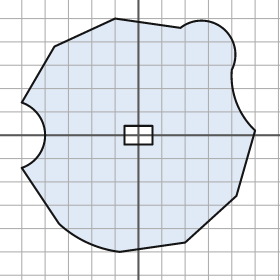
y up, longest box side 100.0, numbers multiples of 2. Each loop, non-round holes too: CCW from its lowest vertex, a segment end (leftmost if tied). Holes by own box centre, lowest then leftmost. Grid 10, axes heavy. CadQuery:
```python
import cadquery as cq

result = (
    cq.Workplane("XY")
    .moveTo(-8.0, -50.0)
    .lineTo(20.0, -46.0)
    .lineTo(42.0, -26.0)
    .lineTo(50.0, 2.0)
    .threePointArc((42.0, 14.0), (40.0, 28.0))
    .threePointArc((36.0, 46.0), (18.0, 46.0))
    .lineTo(-10.0, 50.0)
    .lineTo(-36.0, 38.0)
    .lineTo(-50.0, 14.0)
    .threePointArc((-40.0, 0.0), (-50.0, -14.0))
    .lineTo(-34.0, -38.0)
    .threePointArc((-22.0, -46.0), (-8.0, -50.0))
    .close()
    .moveTo(-6.0, -4.0)
    .lineTo(6.0, -4.0)
    .lineTo(6.0, 4.0)
    .lineTo(-6.0, 4.0)
    .close()
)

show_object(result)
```